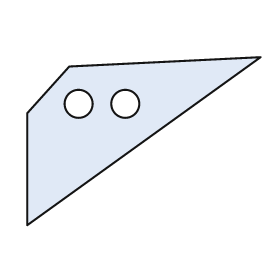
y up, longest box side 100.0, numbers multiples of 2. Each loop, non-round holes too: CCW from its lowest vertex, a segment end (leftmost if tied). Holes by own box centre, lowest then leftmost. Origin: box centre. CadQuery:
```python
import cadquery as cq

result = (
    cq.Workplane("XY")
    .moveTo(-50.0, -36.0)
    .lineTo(50.0, 36.0)
    .lineTo(-32.0, 32.0)
    .lineTo(-50.0, 12.0)
    .close()
    .moveTo(-28.0, 16.0)
    .circle(6.0)
    .moveTo(-8.0, 16.0)
    .circle(6.0)
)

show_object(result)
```